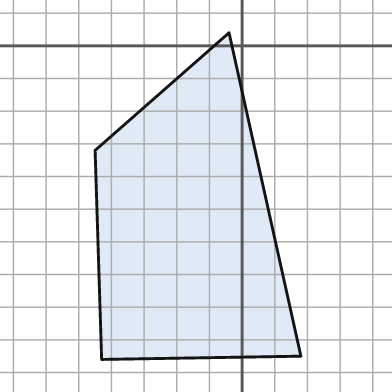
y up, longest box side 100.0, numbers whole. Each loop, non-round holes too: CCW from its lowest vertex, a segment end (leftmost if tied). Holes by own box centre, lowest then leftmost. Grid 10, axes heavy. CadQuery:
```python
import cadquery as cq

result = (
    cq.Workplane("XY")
    .moveTo(-43.0, -96.0)
    .lineTo(18.0, -95.0)
    .lineTo(-4.0, 4.0)
    .lineTo(-45.0, -32.0)
    .close()
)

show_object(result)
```